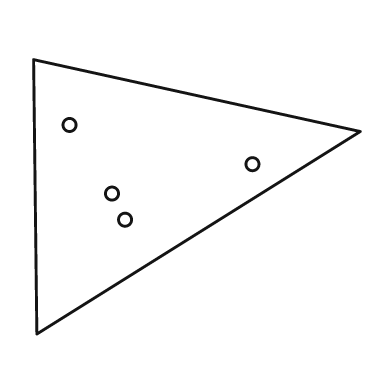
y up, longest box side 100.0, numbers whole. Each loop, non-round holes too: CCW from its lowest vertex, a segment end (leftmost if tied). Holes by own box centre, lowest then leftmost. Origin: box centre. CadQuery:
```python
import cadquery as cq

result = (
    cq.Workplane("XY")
    .moveTo(-49.0, -42.0)
    .lineTo(50.0, 20.0)
    .lineTo(-50.0, 42.0)
    .close()
    .moveTo(-22.0, -7.0)
    .circle(2.0)
    .moveTo(-26.0, 1.0)
    .circle(2.0)
    .moveTo(17.0, 10.0)
    .circle(2.0)
    .moveTo(-39.0, 22.0)
    .circle(2.0)
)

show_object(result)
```